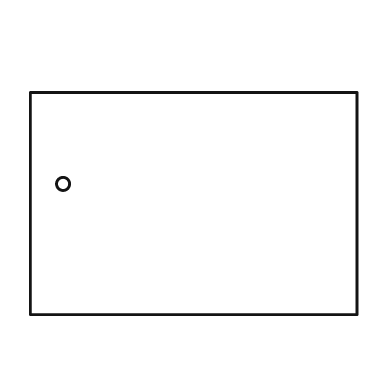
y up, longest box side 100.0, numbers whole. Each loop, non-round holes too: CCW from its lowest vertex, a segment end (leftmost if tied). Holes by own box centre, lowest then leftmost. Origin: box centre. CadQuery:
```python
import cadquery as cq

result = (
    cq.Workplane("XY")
    .moveTo(-50.0, -34.0)
    .lineTo(50.0, -34.0)
    .lineTo(50.0, 34.0)
    .lineTo(-50.0, 34.0)
    .close()
    .moveTo(-40.0, 6.0)
    .circle(2.0)
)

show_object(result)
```